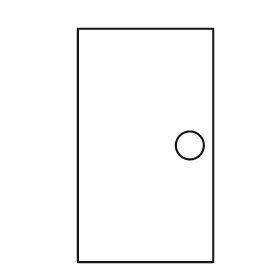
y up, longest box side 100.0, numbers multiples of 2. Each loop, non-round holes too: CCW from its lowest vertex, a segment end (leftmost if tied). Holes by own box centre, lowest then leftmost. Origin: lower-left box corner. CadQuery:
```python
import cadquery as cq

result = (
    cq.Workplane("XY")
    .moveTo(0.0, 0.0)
    .lineTo(58.0, 0.0)
    .lineTo(58.0, 100.0)
    .lineTo(0.0, 100.0)
    .close()
    .moveTo(48.0, 50.0)
    .circle(6.0)
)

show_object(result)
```